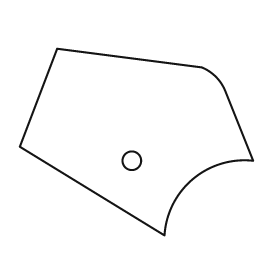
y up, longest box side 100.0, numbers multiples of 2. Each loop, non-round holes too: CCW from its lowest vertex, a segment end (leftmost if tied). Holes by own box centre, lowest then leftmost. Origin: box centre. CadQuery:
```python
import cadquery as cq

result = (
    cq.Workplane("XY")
    .moveTo(12.0, -40.0)
    .threePointArc((24.0, -16.0), (50.0, -8.0))
    .lineTo(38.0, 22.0)
    .threePointArc((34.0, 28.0), (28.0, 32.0))
    .lineTo(-34.0, 40.0)
    .lineTo(-50.0, -2.0)
    .close()
    .moveTo(-2.0, -8.0)
    .circle(4.0)
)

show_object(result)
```